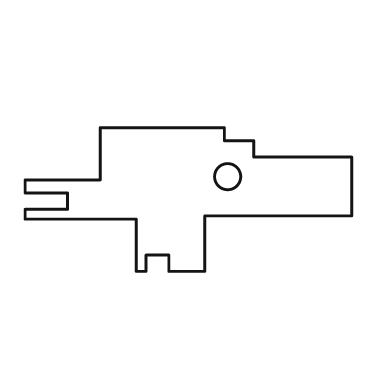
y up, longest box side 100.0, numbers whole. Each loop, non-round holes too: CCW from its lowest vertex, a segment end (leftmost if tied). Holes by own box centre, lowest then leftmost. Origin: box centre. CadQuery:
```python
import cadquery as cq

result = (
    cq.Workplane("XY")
    .moveTo(-16.0, -22.0)
    .lineTo(-13.0, -22.0)
    .lineTo(-13.0, -17.0)
    .lineTo(-6.0, -17.0)
    .lineTo(-6.0, -22.0)
    .lineTo(5.0, -22.0)
    .lineTo(5.0, -5.0)
    .lineTo(50.0, -5.0)
    .lineTo(50.0, 13.0)
    .lineTo(20.0, 13.0)
    .lineTo(20.0, 18.0)
    .lineTo(11.0, 18.0)
    .lineTo(11.0, 22.0)
    .lineTo(-27.0, 22.0)
    .lineTo(-27.0, 6.0)
    .lineTo(-50.0, 6.0)
    .lineTo(-50.0, 2.0)
    .lineTo(-37.0, 2.0)
    .lineTo(-37.0, -3.0)
    .lineTo(-50.0, -3.0)
    .lineTo(-50.0, -6.0)
    .lineTo(-16.0, -6.0)
    .close()
    .moveTo(12.0, 7.0)
    .circle(4.0)
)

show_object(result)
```